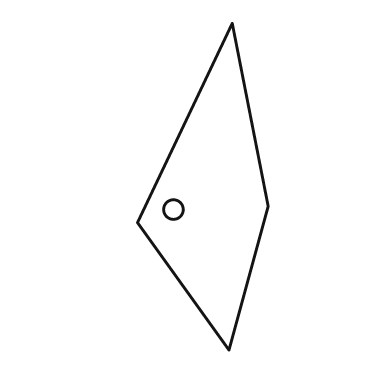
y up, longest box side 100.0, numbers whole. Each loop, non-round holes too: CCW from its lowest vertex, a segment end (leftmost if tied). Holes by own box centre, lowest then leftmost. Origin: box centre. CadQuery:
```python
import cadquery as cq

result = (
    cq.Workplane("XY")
    .moveTo(8.0, -50.0)
    .lineTo(20.0, -6.0)
    .lineTo(9.0, 50.0)
    .lineTo(-20.0, -11.0)
    .close()
    .moveTo(-9.0, -7.0)
    .circle(3.0)
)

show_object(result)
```